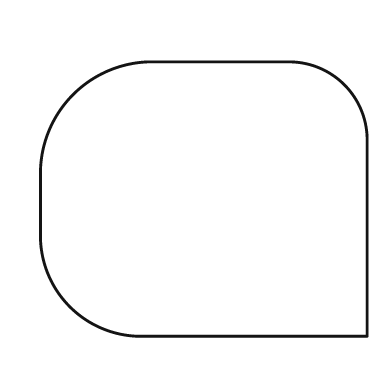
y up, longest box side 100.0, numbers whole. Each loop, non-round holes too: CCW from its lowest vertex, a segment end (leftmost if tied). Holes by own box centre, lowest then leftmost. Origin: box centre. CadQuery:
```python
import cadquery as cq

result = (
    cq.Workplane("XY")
    .moveTo(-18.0, -42.0)
    .lineTo(50.0, -42.0)
    .lineTo(50.0, 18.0)
    .threePointArc((43.0, 35.0), (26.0, 42.0))
    .lineTo(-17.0, 42.0)
    .threePointArc((-40.0, 32.0), (-50.0, 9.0))
    .lineTo(-50.0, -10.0)
    .threePointArc((-41.0, -33.0), (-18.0, -42.0))
    .close()
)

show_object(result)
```